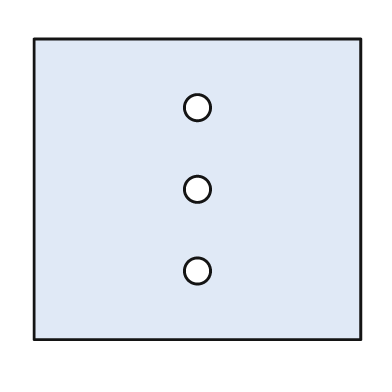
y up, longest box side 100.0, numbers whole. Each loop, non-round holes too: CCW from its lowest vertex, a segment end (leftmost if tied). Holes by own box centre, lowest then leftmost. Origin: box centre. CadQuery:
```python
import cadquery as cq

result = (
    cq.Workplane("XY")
    .moveTo(-50.0, -46.0)
    .lineTo(50.0, -46.0)
    .lineTo(50.0, 46.0)
    .lineTo(-50.0, 46.0)
    .close()
    .moveTo(0.0, -25.0)
    .circle(4.0)
    .moveTo(0.0, 0.0)
    .circle(4.0)
    .moveTo(0.0, 25.0)
    .circle(4.0)
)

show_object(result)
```